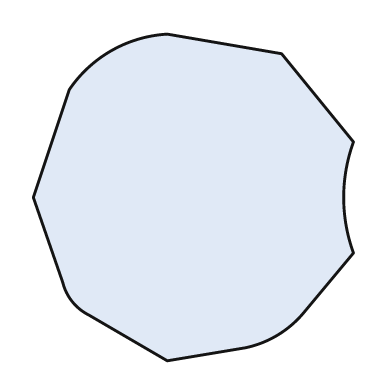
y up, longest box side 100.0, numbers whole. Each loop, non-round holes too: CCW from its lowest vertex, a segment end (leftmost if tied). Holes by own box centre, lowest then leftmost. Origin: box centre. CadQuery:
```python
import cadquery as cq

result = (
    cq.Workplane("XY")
    .moveTo(-8.0, -50.0)
    .lineTo(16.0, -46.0)
    .threePointArc((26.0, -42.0), (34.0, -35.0))
    .lineTo(49.0, -17.0)
    .threePointArc((46.0, 0.0), (49.0, 17.0))
    .lineTo(27.0, 44.0)
    .lineTo(-8.0, 50.0)
    .threePointArc((-25.0, 45.0), (-38.0, 33.0))
    .lineTo(-49.0, 0.0)
    .lineTo(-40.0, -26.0)
    .threePointArc((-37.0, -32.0), (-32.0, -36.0))
    .close()
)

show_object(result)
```